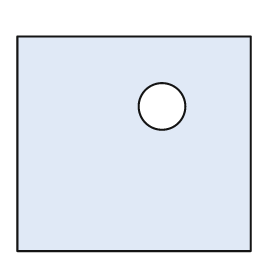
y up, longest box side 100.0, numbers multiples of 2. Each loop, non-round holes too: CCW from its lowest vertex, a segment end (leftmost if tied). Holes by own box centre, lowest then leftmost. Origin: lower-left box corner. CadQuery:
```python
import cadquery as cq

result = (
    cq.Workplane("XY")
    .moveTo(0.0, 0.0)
    .lineTo(100.0, 0.0)
    .lineTo(100.0, 92.0)
    .lineTo(0.0, 92.0)
    .close()
    .moveTo(62.0, 62.0)
    .circle(10.0)
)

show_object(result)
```